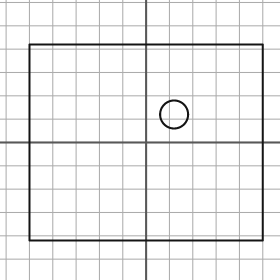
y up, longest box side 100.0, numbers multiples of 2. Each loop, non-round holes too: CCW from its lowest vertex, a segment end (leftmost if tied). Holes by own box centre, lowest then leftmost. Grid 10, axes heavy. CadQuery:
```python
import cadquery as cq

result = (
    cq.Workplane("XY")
    .moveTo(-50.0, -42.0)
    .lineTo(50.0, -42.0)
    .lineTo(50.0, 42.0)
    .lineTo(-50.0, 42.0)
    .close()
    .moveTo(12.0, 12.0)
    .circle(6.0)
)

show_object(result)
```